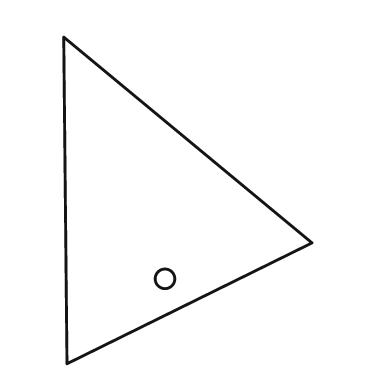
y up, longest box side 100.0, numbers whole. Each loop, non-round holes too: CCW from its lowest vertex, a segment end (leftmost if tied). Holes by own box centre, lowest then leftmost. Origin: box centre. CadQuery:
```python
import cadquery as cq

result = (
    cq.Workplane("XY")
    .moveTo(-37.0, -50.0)
    .lineTo(38.0, -13.0)
    .lineTo(-38.0, 50.0)
    .close()
    .moveTo(-7.0, -24.0)
    .circle(3.0)
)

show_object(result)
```